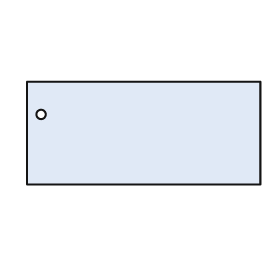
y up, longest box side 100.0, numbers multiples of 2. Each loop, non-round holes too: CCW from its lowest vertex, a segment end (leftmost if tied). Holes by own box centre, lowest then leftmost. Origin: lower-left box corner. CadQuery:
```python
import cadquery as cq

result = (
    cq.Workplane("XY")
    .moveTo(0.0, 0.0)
    .lineTo(100.0, 0.0)
    .lineTo(100.0, 44.0)
    .lineTo(0.0, 44.0)
    .close()
    .moveTo(6.0, 30.0)
    .circle(2.0)
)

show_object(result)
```